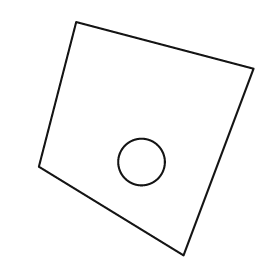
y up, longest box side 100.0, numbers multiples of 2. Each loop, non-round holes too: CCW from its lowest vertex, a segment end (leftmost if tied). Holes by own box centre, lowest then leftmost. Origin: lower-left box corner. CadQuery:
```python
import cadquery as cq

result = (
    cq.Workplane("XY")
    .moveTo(62.0, 0.0)
    .lineTo(92.0, 80.0)
    .lineTo(16.0, 100.0)
    .lineTo(0.0, 38.0)
    .close()
    .moveTo(44.0, 40.0)
    .circle(10.0)
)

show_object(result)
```